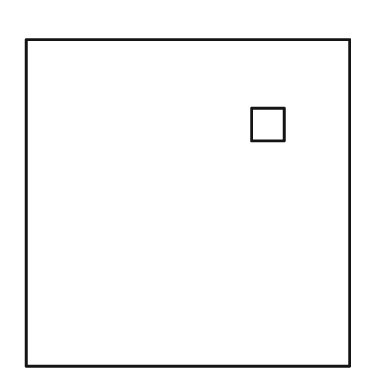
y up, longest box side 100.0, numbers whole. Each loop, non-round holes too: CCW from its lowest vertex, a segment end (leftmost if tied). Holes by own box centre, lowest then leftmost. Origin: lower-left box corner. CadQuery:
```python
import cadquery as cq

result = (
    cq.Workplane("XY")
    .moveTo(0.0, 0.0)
    .lineTo(99.0, 0.0)
    .lineTo(99.0, 100.0)
    .lineTo(0.0, 100.0)
    .close()
    .moveTo(69.0, 69.0)
    .lineTo(79.0, 69.0)
    .lineTo(79.0, 79.0)
    .lineTo(69.0, 79.0)
    .close()
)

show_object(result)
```